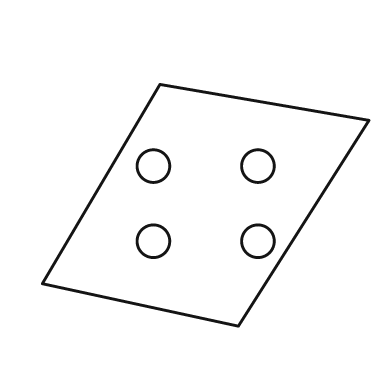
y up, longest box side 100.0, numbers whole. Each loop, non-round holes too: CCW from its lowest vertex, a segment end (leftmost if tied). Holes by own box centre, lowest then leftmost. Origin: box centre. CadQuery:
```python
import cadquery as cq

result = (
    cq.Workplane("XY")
    .moveTo(10.0, -37.0)
    .lineTo(50.0, 26.0)
    .lineTo(-14.0, 37.0)
    .lineTo(-50.0, -24.0)
    .close()
    .moveTo(-16.0, -11.0)
    .circle(5.0)
    .moveTo(16.0, -11.0)
    .circle(5.0)
    .moveTo(-16.0, 12.0)
    .circle(5.0)
    .moveTo(16.0, 12.0)
    .circle(5.0)
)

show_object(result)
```